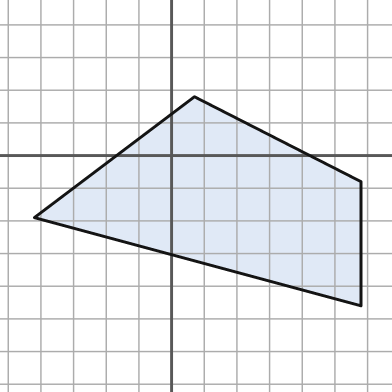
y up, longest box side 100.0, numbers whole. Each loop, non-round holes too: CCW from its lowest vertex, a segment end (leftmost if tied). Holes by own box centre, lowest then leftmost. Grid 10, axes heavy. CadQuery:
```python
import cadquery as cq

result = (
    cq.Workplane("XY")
    .moveTo(58.0, -46.0)
    .lineTo(58.0, -8.0)
    .lineTo(7.0, 18.0)
    .lineTo(-42.0, -19.0)
    .close()
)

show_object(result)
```